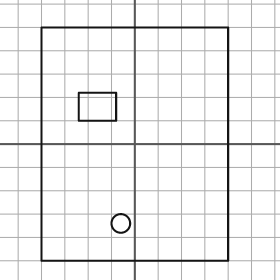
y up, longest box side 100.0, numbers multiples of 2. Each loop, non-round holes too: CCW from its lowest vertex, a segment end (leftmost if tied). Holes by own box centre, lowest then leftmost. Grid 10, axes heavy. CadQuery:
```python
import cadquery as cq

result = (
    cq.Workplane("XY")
    .moveTo(-40.0, -50.0)
    .lineTo(40.0, -50.0)
    .lineTo(40.0, 50.0)
    .lineTo(-40.0, 50.0)
    .close()
    .moveTo(-6.0, -34.0)
    .circle(4.0)
    .moveTo(-24.0, 10.0)
    .lineTo(-8.0, 10.0)
    .lineTo(-8.0, 22.0)
    .lineTo(-24.0, 22.0)
    .close()
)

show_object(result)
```